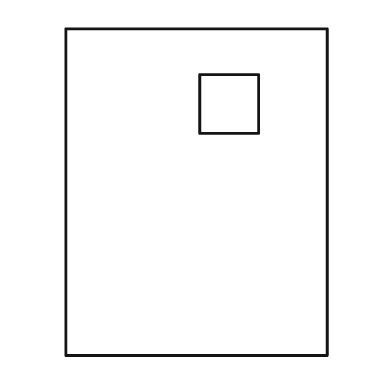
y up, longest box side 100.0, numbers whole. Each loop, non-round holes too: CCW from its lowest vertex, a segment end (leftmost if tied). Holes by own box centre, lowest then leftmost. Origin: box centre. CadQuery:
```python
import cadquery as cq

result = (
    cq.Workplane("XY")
    .moveTo(-40.0, -50.0)
    .lineTo(40.0, -50.0)
    .lineTo(40.0, 50.0)
    .lineTo(-40.0, 50.0)
    .close()
    .moveTo(1.0, 18.0)
    .lineTo(19.0, 18.0)
    .lineTo(19.0, 36.0)
    .lineTo(1.0, 36.0)
    .close()
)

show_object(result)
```